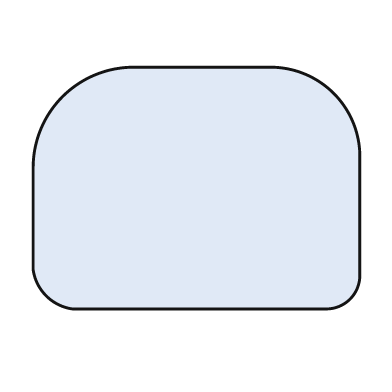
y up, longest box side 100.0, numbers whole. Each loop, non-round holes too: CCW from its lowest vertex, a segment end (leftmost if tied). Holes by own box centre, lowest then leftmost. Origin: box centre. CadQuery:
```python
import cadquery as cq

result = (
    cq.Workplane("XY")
    .moveTo(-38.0, -37.0)
    .lineTo(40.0, -37.0)
    .threePointArc((47.0, -34.0), (50.0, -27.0))
    .lineTo(50.0, 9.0)
    .threePointArc((42.0, 29.0), (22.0, 37.0))
    .lineTo(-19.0, 37.0)
    .threePointArc((-41.0, 28.0), (-50.0, 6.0))
    .lineTo(-50.0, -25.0)
    .threePointArc((-46.0, -33.0), (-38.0, -37.0))
    .close()
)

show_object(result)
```